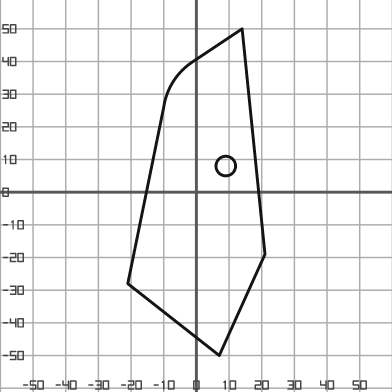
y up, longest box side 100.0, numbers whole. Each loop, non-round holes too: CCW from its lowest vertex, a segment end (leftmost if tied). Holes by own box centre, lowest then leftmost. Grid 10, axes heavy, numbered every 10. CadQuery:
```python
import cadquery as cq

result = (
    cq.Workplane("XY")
    .moveTo(7.0, -50.0)
    .lineTo(21.0, -19.0)
    .lineTo(14.0, 50.0)
    .lineTo(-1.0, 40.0)
    .threePointArc((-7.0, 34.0), (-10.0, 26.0))
    .lineTo(-21.0, -28.0)
    .close()
    .moveTo(9.0, 8.0)
    .circle(3.0)
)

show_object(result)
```